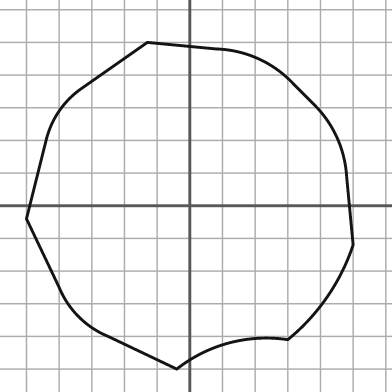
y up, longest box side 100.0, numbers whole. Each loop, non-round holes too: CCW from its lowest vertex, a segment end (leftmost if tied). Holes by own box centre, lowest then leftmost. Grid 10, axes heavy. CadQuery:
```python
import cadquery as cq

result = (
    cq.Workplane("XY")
    .moveTo(-4.0, -50.0)
    .threePointArc((12.0, -42.0), (30.0, -41.0))
    .threePointArc((42.0, -28.0), (50.0, -12.0))
    .lineTo(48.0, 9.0)
    .threePointArc((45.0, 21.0), (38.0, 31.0))
    .lineTo(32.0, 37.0)
    .threePointArc((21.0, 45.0), (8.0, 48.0))
    .lineTo(-13.0, 50.0)
    .lineTo(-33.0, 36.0)
    .threePointArc((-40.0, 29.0), (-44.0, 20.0))
    .lineTo(-50.0, -4.0)
    .lineTo(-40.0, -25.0)
    .threePointArc((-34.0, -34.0), (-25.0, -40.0))
    .close()
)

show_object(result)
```